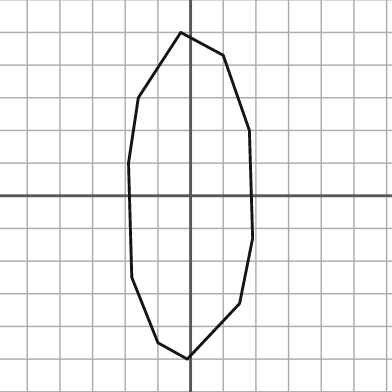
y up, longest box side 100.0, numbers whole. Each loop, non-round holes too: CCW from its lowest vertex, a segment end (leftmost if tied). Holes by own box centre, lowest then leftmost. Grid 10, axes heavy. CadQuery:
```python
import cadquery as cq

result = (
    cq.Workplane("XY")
    .moveTo(-1.0, -50.0)
    .lineTo(15.0, -33.0)
    .lineTo(19.0, -13.0)
    .lineTo(18.0, 20.0)
    .lineTo(10.0, 43.0)
    .lineTo(-3.0, 50.0)
    .lineTo(-16.0, 30.0)
    .lineTo(-19.0, 10.0)
    .lineTo(-18.0, -25.0)
    .lineTo(-10.0, -45.0)
    .close()
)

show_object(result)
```